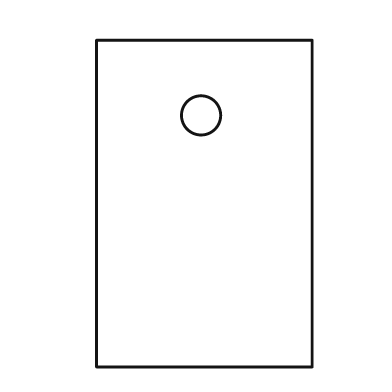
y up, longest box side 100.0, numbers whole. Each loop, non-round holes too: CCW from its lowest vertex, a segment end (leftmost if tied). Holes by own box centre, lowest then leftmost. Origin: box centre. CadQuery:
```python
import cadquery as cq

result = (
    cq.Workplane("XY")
    .moveTo(-33.0, -50.0)
    .lineTo(33.0, -50.0)
    .lineTo(33.0, 50.0)
    .lineTo(-33.0, 50.0)
    .close()
    .moveTo(-1.0, 27.0)
    .circle(6.0)
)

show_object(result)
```